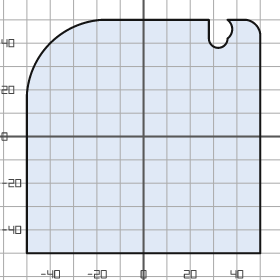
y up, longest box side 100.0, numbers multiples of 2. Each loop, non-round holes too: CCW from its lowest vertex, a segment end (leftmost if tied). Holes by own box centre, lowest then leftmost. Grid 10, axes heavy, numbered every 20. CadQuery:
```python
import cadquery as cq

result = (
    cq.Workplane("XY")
    .moveTo(-50.0, -50.0)
    .lineTo(50.0, -50.0)
    .lineTo(50.0, 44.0)
    .threePointArc((48.0, 48.0), (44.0, 50.0))
    .lineTo(36.0, 50.0)
    .threePointArc((38.0, 46.0), (36.0, 42.0))
    .threePointArc((32.0, 38.0), (28.0, 42.0))
    .lineTo(28.0, 50.0)
    .lineTo(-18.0, 50.0)
    .threePointArc((-40.0, 40.0), (-50.0, 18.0))
    .close()
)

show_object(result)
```